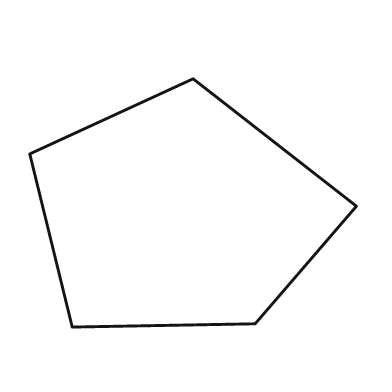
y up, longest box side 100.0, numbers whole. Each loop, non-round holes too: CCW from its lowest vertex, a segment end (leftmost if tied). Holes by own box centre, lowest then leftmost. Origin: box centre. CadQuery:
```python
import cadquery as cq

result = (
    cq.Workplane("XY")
    .moveTo(-37.0, -38.0)
    .lineTo(19.0, -37.0)
    .lineTo(50.0, -1.0)
    .lineTo(0.0, 38.0)
    .lineTo(-50.0, 15.0)
    .close()
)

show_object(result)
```